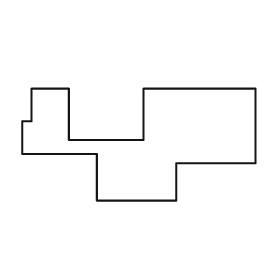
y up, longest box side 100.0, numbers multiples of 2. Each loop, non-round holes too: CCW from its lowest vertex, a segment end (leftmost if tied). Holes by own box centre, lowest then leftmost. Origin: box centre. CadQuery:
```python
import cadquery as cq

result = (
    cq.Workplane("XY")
    .moveTo(-18.0, -24.0)
    .lineTo(16.0, -24.0)
    .lineTo(16.0, -8.0)
    .lineTo(50.0, -8.0)
    .lineTo(50.0, 24.0)
    .lineTo(2.0, 24.0)
    .lineTo(2.0, 2.0)
    .lineTo(-30.0, 2.0)
    .lineTo(-30.0, 24.0)
    .lineTo(-46.0, 24.0)
    .lineTo(-46.0, 10.0)
    .lineTo(-50.0, 10.0)
    .lineTo(-50.0, -4.0)
    .lineTo(-18.0, -4.0)
    .close()
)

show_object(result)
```